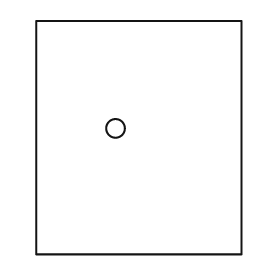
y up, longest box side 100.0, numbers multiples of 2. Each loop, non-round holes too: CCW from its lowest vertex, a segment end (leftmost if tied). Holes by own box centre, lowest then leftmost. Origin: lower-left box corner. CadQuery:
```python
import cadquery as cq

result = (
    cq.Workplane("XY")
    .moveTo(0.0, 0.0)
    .lineTo(88.0, 0.0)
    .lineTo(88.0, 100.0)
    .lineTo(0.0, 100.0)
    .close()
    .moveTo(34.0, 54.0)
    .circle(4.0)
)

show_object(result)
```